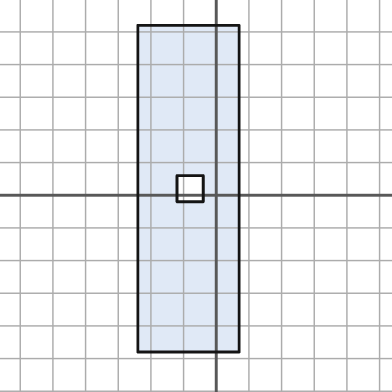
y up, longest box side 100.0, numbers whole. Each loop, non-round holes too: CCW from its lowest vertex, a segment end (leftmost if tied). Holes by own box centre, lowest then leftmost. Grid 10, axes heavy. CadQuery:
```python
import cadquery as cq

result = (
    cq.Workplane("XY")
    .moveTo(-24.0, -48.0)
    .lineTo(7.0, -48.0)
    .lineTo(7.0, 52.0)
    .lineTo(-24.0, 52.0)
    .close()
    .moveTo(-12.0, -2.0)
    .lineTo(-4.0, -2.0)
    .lineTo(-4.0, 6.0)
    .lineTo(-12.0, 6.0)
    .close()
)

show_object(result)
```